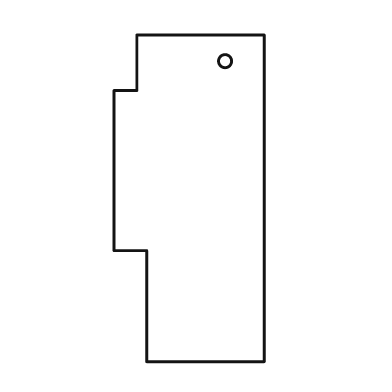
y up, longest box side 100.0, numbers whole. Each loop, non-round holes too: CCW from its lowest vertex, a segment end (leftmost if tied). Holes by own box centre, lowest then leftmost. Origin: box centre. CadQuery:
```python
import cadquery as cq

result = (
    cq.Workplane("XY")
    .moveTo(-13.0, -50.0)
    .lineTo(23.0, -50.0)
    .lineTo(23.0, 50.0)
    .lineTo(-16.0, 50.0)
    .lineTo(-16.0, 33.0)
    .lineTo(-23.0, 33.0)
    .lineTo(-23.0, -16.0)
    .lineTo(-13.0, -16.0)
    .close()
    .moveTo(11.0, 42.0)
    .circle(2.0)
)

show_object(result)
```